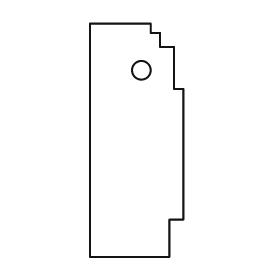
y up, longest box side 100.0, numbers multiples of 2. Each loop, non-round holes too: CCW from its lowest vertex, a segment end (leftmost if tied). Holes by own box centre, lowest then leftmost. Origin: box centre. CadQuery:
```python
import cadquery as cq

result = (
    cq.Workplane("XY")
    .moveTo(-20.0, -50.0)
    .lineTo(14.0, -50.0)
    .lineTo(14.0, -34.0)
    .lineTo(20.0, -34.0)
    .lineTo(20.0, 22.0)
    .lineTo(16.0, 22.0)
    .lineTo(16.0, 40.0)
    .lineTo(10.0, 40.0)
    .lineTo(10.0, 46.0)
    .lineTo(6.0, 46.0)
    .lineTo(6.0, 50.0)
    .lineTo(-20.0, 50.0)
    .close()
    .moveTo(2.0, 30.0)
    .circle(4.0)
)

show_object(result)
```